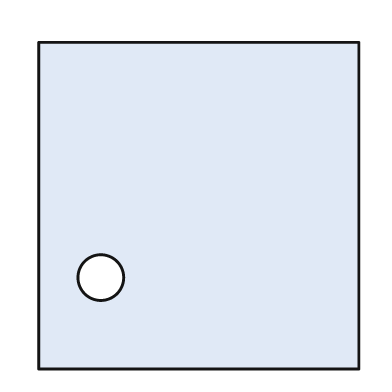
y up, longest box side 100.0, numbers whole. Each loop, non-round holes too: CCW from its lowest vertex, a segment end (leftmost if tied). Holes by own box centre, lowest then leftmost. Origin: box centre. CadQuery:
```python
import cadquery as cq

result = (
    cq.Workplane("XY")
    .moveTo(-49.0, -50.0)
    .lineTo(49.0, -50.0)
    .lineTo(49.0, 50.0)
    .lineTo(-49.0, 50.0)
    .close()
    .moveTo(-30.0, -22.0)
    .circle(7.0)
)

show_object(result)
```